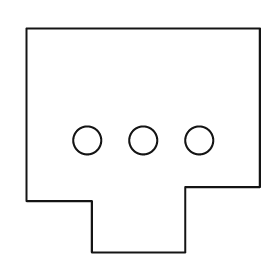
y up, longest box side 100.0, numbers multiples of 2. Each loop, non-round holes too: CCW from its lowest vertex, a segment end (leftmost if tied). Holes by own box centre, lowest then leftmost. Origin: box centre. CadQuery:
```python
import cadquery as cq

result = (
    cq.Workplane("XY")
    .moveTo(-22.0, -48.0)
    .lineTo(18.0, -48.0)
    .lineTo(18.0, -20.0)
    .lineTo(50.0, -20.0)
    .lineTo(50.0, 48.0)
    .lineTo(-50.0, 48.0)
    .lineTo(-50.0, -26.0)
    .lineTo(-22.0, -26.0)
    .close()
    .moveTo(-24.0, 0.0)
    .circle(6.0)
    .moveTo(0.0, 0.0)
    .circle(6.0)
    .moveTo(24.0, 0.0)
    .circle(6.0)
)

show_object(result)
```